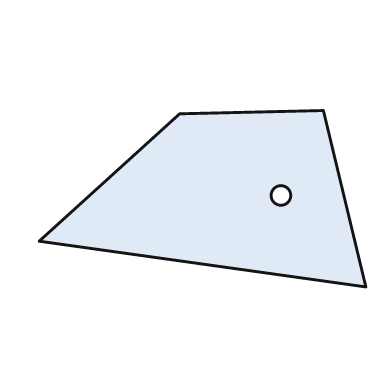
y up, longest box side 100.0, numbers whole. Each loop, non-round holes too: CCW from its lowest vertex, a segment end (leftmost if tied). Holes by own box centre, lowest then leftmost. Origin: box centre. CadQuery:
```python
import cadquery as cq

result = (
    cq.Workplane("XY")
    .moveTo(50.0, -27.0)
    .lineTo(37.0, 27.0)
    .lineTo(-7.0, 26.0)
    .lineTo(-50.0, -13.0)
    .close()
    .moveTo(24.0, 1.0)
    .circle(3.0)
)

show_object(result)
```